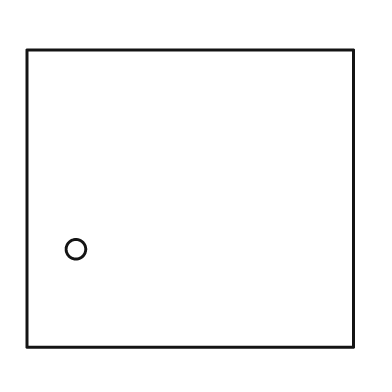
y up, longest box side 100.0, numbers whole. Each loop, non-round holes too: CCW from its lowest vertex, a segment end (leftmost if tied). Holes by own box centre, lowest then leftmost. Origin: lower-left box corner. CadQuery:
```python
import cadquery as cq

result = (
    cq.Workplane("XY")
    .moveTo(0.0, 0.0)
    .lineTo(100.0, 0.0)
    .lineTo(100.0, 91.0)
    .lineTo(0.0, 91.0)
    .close()
    .moveTo(15.0, 30.0)
    .circle(3.0)
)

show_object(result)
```